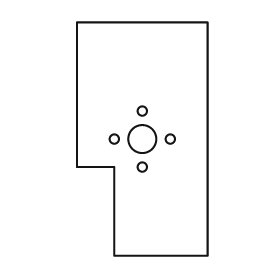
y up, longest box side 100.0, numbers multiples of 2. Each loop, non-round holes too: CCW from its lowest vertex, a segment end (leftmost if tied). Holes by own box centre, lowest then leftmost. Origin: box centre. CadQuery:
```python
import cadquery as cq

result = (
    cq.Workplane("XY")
    .moveTo(-12.0, -50.0)
    .lineTo(28.0, -50.0)
    .lineTo(28.0, 50.0)
    .lineTo(-28.0, 50.0)
    .lineTo(-28.0, -12.0)
    .lineTo(-12.0, -12.0)
    .close()
    .moveTo(0.0, -12.0)
    .circle(2.0)
    .moveTo(-12.0, 0.0)
    .circle(2.0)
    .moveTo(0.0, 0.0)
    .circle(6.0)
    .moveTo(12.0, 0.0)
    .circle(2.0)
    .moveTo(0.0, 12.0)
    .circle(2.0)
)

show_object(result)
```